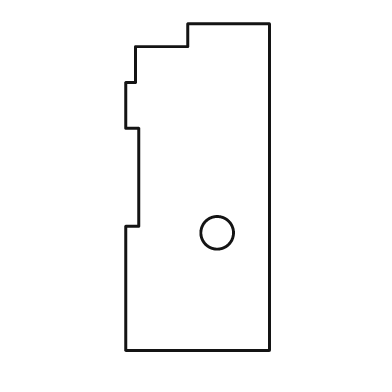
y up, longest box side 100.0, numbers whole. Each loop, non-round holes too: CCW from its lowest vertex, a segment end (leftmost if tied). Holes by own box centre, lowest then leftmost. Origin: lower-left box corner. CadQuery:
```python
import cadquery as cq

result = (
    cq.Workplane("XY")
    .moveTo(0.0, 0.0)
    .lineTo(44.0, 0.0)
    .lineTo(44.0, 100.0)
    .lineTo(19.0, 100.0)
    .lineTo(19.0, 93.0)
    .lineTo(3.0, 93.0)
    .lineTo(3.0, 82.0)
    .lineTo(0.0, 82.0)
    .lineTo(0.0, 68.0)
    .lineTo(4.0, 68.0)
    .lineTo(4.0, 38.0)
    .lineTo(0.0, 38.0)
    .close()
    .moveTo(28.0, 36.0)
    .circle(5.0)
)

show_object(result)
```